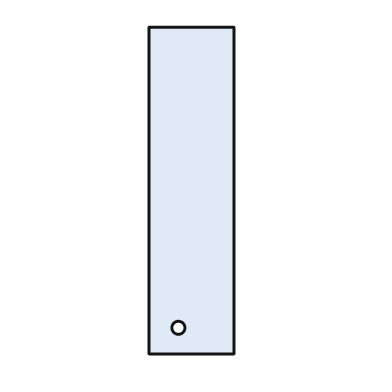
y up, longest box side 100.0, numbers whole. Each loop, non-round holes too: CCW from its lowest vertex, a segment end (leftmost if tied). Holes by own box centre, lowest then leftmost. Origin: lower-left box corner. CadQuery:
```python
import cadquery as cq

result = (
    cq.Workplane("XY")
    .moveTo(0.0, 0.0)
    .lineTo(26.0, 0.0)
    .lineTo(26.0, 100.0)
    .lineTo(0.0, 100.0)
    .close()
    .moveTo(9.0, 8.0)
    .circle(2.0)
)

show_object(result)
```